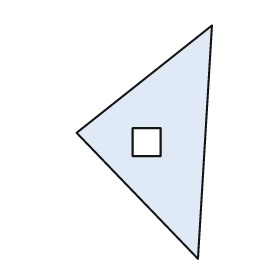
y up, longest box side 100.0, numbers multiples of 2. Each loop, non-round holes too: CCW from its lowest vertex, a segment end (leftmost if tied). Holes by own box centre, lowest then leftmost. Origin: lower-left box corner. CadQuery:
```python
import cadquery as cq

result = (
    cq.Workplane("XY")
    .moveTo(52.0, 0.0)
    .lineTo(58.0, 100.0)
    .lineTo(0.0, 54.0)
    .close()
    .moveTo(24.0, 44.0)
    .lineTo(36.0, 44.0)
    .lineTo(36.0, 56.0)
    .lineTo(24.0, 56.0)
    .close()
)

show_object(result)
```